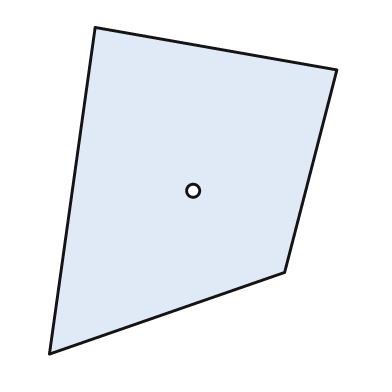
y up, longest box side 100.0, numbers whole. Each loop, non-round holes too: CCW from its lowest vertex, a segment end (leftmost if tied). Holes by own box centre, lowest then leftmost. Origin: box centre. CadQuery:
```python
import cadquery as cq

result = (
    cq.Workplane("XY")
    .moveTo(-44.0, -50.0)
    .lineTo(28.0, -25.0)
    .lineTo(44.0, 37.0)
    .lineTo(-30.0, 50.0)
    .close()
    .moveTo(0.0, 0.0)
    .circle(2.0)
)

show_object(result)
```